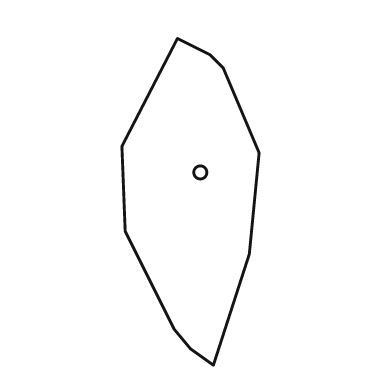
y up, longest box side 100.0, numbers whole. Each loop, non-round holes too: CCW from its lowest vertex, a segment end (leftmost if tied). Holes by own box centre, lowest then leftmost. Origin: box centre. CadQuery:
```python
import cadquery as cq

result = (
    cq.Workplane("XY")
    .moveTo(7.0, -50.0)
    .lineTo(18.0, -16.0)
    .lineTo(21.0, 15.0)
    .lineTo(10.0, 41.0)
    .lineTo(6.0, 45.0)
    .lineTo(-4.0, 50.0)
    .lineTo(-21.0, 17.0)
    .lineTo(-20.0, -9.0)
    .lineTo(-5.0, -39.0)
    .lineTo(0.0, -45.0)
    .close()
    .moveTo(3.0, 9.0)
    .circle(2.0)
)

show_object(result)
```